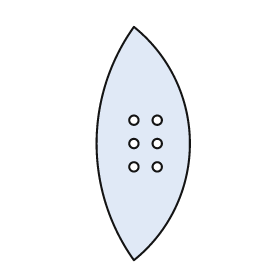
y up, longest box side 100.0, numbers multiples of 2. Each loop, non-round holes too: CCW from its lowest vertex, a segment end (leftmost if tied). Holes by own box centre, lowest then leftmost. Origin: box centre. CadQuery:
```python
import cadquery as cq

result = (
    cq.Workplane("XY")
    .moveTo(-4.0, -50.0)
    .threePointArc((20.0, 0.0), (-4.0, 50.0))
    .threePointArc((-20.0, 0.0), (-4.0, -50.0))
    .close()
    .moveTo(-4.0, -10.0)
    .circle(2.0)
    .moveTo(6.0, -10.0)
    .circle(2.0)
    .moveTo(-4.0, 0.0)
    .circle(2.0)
    .moveTo(6.0, 0.0)
    .circle(2.0)
    .moveTo(-4.0, 10.0)
    .circle(2.0)
    .moveTo(6.0, 10.0)
    .circle(2.0)
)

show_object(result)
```